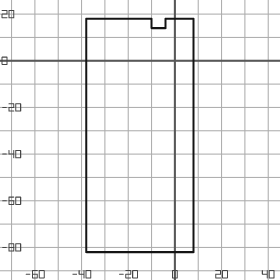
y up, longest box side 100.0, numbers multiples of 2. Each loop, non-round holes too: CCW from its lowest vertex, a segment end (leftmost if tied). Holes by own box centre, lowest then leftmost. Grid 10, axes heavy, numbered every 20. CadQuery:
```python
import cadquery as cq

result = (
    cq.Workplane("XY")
    .moveTo(-38.0, -82.0)
    .lineTo(8.0, -82.0)
    .lineTo(8.0, 18.0)
    .lineTo(-4.0, 18.0)
    .lineTo(-4.0, 14.0)
    .lineTo(-10.0, 14.0)
    .lineTo(-10.0, 18.0)
    .lineTo(-38.0, 18.0)
    .close()
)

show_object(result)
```